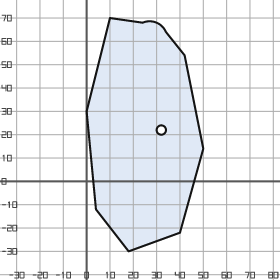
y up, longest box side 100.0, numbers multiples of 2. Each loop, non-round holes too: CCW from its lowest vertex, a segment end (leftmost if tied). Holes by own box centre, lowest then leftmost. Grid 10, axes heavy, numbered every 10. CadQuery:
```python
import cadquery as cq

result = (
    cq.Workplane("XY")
    .moveTo(18.0, -30.0)
    .lineTo(40.0, -22.0)
    .lineTo(50.0, 14.0)
    .lineTo(42.0, 54.0)
    .lineTo(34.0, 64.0)
    .threePointArc((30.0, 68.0), (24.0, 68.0))
    .lineTo(10.0, 70.0)
    .lineTo(0.0, 30.0)
    .lineTo(4.0, -12.0)
    .close()
    .moveTo(32.0, 22.0)
    .circle(2.0)
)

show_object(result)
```